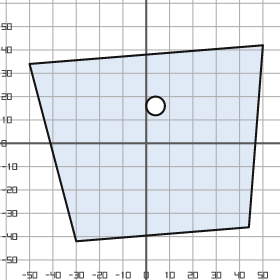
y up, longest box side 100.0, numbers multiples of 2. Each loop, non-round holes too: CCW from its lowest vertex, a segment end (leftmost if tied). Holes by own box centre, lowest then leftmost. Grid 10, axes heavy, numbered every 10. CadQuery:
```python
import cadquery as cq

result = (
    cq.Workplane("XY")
    .moveTo(-30.0, -42.0)
    .lineTo(44.0, -36.0)
    .lineTo(50.0, 42.0)
    .lineTo(-50.0, 34.0)
    .close()
    .moveTo(4.0, 16.0)
    .circle(4.0)
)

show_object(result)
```